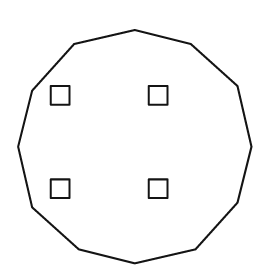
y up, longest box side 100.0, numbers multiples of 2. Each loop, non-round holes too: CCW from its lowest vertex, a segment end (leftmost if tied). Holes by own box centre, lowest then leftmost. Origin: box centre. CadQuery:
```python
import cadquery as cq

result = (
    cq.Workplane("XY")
    .moveTo(0.0, -50.0)
    .lineTo(26.0, -44.0)
    .lineTo(44.0, -24.0)
    .lineTo(50.0, 0.0)
    .lineTo(44.0, 26.0)
    .lineTo(24.0, 44.0)
    .lineTo(0.0, 50.0)
    .lineTo(-26.0, 44.0)
    .lineTo(-44.0, 24.0)
    .lineTo(-50.0, 0.0)
    .lineTo(-44.0, -26.0)
    .lineTo(-24.0, -44.0)
    .close()
    .moveTo(-36.0, -22.0)
    .lineTo(-28.0, -22.0)
    .lineTo(-28.0, -14.0)
    .lineTo(-36.0, -14.0)
    .close()
    .moveTo(6.0, -22.0)
    .lineTo(14.0, -22.0)
    .lineTo(14.0, -14.0)
    .lineTo(6.0, -14.0)
    .close()
    .moveTo(-36.0, 18.0)
    .lineTo(-28.0, 18.0)
    .lineTo(-28.0, 26.0)
    .lineTo(-36.0, 26.0)
    .close()
    .moveTo(6.0, 18.0)
    .lineTo(14.0, 18.0)
    .lineTo(14.0, 26.0)
    .lineTo(6.0, 26.0)
    .close()
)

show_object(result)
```